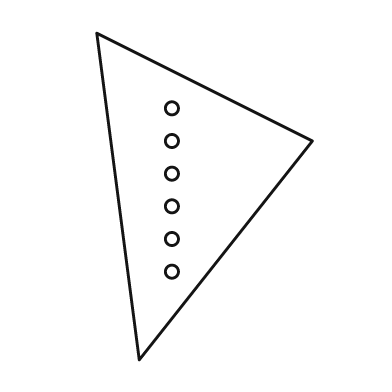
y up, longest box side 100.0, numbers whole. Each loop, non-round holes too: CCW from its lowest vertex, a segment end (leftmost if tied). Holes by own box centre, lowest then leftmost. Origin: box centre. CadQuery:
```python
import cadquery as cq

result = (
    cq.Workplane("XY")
    .moveTo(-20.0, -50.0)
    .lineTo(33.0, 17.0)
    .lineTo(-33.0, 50.0)
    .close()
    .moveTo(-10.0, -23.0)
    .circle(2.0)
    .moveTo(-10.0, -13.0)
    .circle(2.0)
    .moveTo(-10.0, -3.0)
    .circle(2.0)
    .moveTo(-10.0, 7.0)
    .circle(2.0)
    .moveTo(-10.0, 17.0)
    .circle(2.0)
    .moveTo(-10.0, 27.0)
    .circle(2.0)
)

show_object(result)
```